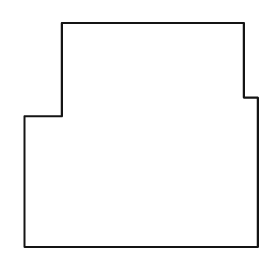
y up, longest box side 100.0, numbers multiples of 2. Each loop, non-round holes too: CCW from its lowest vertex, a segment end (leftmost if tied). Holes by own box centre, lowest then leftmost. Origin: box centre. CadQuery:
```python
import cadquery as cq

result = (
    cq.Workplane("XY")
    .moveTo(-50.0, -48.0)
    .lineTo(50.0, -48.0)
    .lineTo(50.0, 16.0)
    .lineTo(44.0, 16.0)
    .lineTo(44.0, 48.0)
    .lineTo(-34.0, 48.0)
    .lineTo(-34.0, 8.0)
    .lineTo(-50.0, 8.0)
    .close()
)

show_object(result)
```